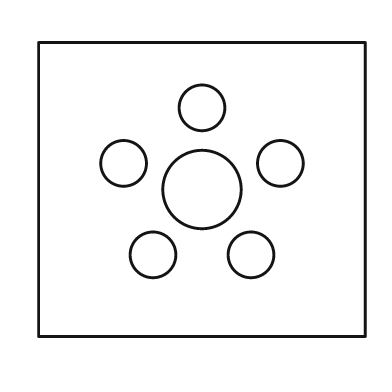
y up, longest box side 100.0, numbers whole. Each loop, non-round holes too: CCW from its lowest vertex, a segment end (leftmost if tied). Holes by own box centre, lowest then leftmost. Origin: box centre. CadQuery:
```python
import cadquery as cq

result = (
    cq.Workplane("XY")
    .moveTo(-50.0, -45.0)
    .lineTo(50.0, -45.0)
    .lineTo(50.0, 45.0)
    .lineTo(-50.0, 45.0)
    .close()
    .moveTo(-15.0, -20.0)
    .circle(7.0)
    .moveTo(15.0, -20.0)
    .circle(7.0)
    .moveTo(0.0, 0.0)
    .circle(12.0)
    .moveTo(-24.0, 8.0)
    .circle(7.0)
    .moveTo(24.0, 8.0)
    .circle(7.0)
    .moveTo(0.0, 25.0)
    .circle(7.0)
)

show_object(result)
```